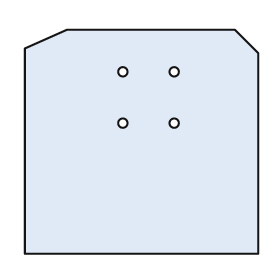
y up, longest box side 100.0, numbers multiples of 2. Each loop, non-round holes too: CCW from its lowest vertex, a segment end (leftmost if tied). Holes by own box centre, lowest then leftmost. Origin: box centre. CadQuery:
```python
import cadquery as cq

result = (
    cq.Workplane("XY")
    .moveTo(-50.0, -48.0)
    .lineTo(50.0, -48.0)
    .lineTo(50.0, 38.0)
    .lineTo(40.0, 48.0)
    .lineTo(-32.0, 48.0)
    .lineTo(-50.0, 40.0)
    .close()
    .moveTo(-8.0, 8.0)
    .circle(2.0)
    .moveTo(14.0, 8.0)
    .circle(2.0)
    .moveTo(-8.0, 30.0)
    .circle(2.0)
    .moveTo(14.0, 30.0)
    .circle(2.0)
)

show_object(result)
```